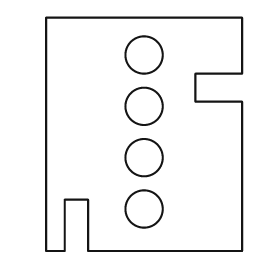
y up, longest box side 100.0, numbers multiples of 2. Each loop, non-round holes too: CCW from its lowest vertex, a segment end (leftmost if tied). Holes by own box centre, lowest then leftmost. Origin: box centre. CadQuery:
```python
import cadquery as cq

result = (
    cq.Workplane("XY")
    .moveTo(-42.0, -50.0)
    .lineTo(-34.0, -50.0)
    .lineTo(-34.0, -28.0)
    .lineTo(-24.0, -28.0)
    .lineTo(-24.0, -50.0)
    .lineTo(42.0, -50.0)
    .lineTo(42.0, 14.0)
    .lineTo(22.0, 14.0)
    .lineTo(22.0, 26.0)
    .lineTo(42.0, 26.0)
    .lineTo(42.0, 50.0)
    .lineTo(-42.0, 50.0)
    .close()
    .moveTo(0.0, -32.0)
    .circle(8.0)
    .moveTo(0.0, -10.0)
    .circle(8.0)
    .moveTo(0.0, 12.0)
    .circle(8.0)
    .moveTo(0.0, 34.0)
    .circle(8.0)
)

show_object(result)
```